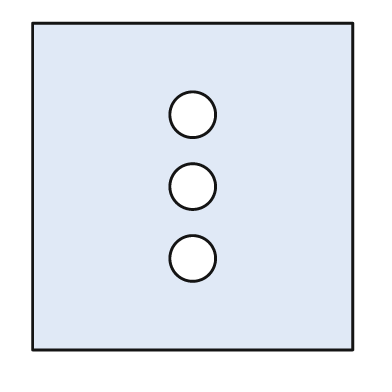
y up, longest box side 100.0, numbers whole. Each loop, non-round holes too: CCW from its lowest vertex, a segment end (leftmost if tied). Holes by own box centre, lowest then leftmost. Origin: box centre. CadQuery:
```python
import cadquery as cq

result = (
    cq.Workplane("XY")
    .moveTo(-49.0, -50.0)
    .lineTo(49.0, -50.0)
    .lineTo(49.0, 50.0)
    .lineTo(-49.0, 50.0)
    .close()
    .moveTo(0.0, -22.0)
    .circle(7.0)
    .moveTo(0.0, 0.0)
    .circle(7.0)
    .moveTo(0.0, 22.0)
    .circle(7.0)
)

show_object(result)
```